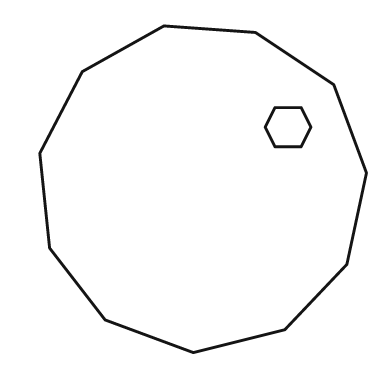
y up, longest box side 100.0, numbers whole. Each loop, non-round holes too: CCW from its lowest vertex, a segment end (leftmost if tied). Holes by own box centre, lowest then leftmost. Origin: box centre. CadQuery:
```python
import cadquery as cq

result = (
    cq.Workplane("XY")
    .moveTo(-3.0, -50.0)
    .lineTo(25.0, -43.0)
    .lineTo(44.0, -23.0)
    .lineTo(50.0, 5.0)
    .lineTo(40.0, 32.0)
    .lineTo(16.0, 48.0)
    .lineTo(-12.0, 50.0)
    .lineTo(-37.0, 36.0)
    .lineTo(-50.0, 11.0)
    .lineTo(-47.0, -18.0)
    .lineTo(-30.0, -40.0)
    .close()
    .moveTo(22.0, 13.0)
    .lineTo(30.0, 13.0)
    .lineTo(33.0, 19.0)
    .lineTo(30.0, 25.0)
    .lineTo(22.0, 25.0)
    .lineTo(19.0, 19.0)
    .close()
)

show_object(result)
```